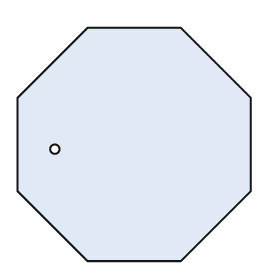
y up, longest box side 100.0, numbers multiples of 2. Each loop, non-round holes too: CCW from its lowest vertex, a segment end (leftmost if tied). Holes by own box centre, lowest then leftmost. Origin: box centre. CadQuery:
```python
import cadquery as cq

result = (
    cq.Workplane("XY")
    .moveTo(-20.0, -50.0)
    .lineTo(20.0, -50.0)
    .lineTo(50.0, -20.0)
    .lineTo(50.0, 20.0)
    .lineTo(20.0, 50.0)
    .lineTo(-20.0, 50.0)
    .lineTo(-50.0, 20.0)
    .lineTo(-50.0, -20.0)
    .close()
    .moveTo(-34.0, -2.0)
    .circle(2.0)
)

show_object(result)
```